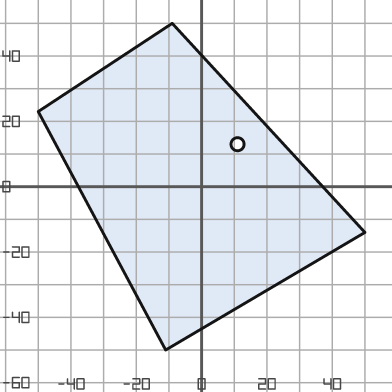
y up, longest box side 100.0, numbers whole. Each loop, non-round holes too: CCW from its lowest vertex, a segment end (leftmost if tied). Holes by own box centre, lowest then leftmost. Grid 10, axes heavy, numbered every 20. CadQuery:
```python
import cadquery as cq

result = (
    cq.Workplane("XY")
    .moveTo(-11.0, -50.0)
    .lineTo(50.0, -14.0)
    .lineTo(-9.0, 50.0)
    .lineTo(-50.0, 23.0)
    .close()
    .moveTo(11.0, 13.0)
    .circle(2.0)
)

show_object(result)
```